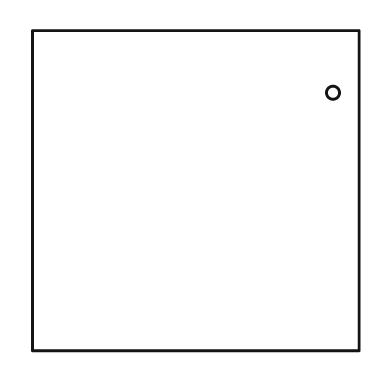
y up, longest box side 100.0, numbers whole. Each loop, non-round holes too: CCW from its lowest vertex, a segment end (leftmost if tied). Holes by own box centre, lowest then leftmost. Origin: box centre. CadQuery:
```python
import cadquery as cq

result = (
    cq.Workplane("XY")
    .moveTo(-50.0, -49.0)
    .lineTo(50.0, -49.0)
    .lineTo(50.0, 49.0)
    .lineTo(-50.0, 49.0)
    .close()
    .moveTo(42.0, 30.0)
    .circle(2.0)
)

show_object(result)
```